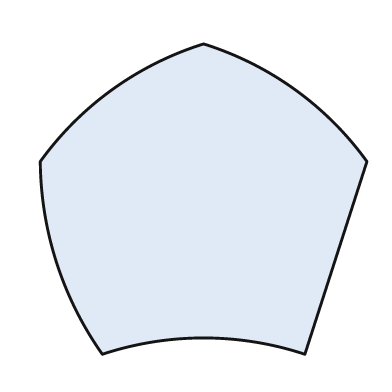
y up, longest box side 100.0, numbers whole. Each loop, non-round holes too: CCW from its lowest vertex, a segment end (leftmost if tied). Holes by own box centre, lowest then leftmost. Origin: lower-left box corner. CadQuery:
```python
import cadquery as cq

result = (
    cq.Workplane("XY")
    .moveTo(19.0, 0.0)
    .threePointArc((50.0, 5.0), (81.0, 0.0))
    .lineTo(100.0, 59.0)
    .threePointArc((78.0, 81.0), (50.0, 95.0))
    .threePointArc((22.0, 81.0), (0.0, 59.0))
    .threePointArc((5.0, 28.0), (19.0, 0.0))
    .close()
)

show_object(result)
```